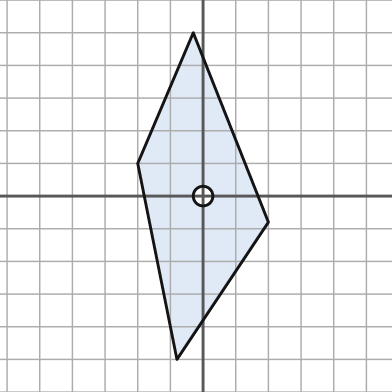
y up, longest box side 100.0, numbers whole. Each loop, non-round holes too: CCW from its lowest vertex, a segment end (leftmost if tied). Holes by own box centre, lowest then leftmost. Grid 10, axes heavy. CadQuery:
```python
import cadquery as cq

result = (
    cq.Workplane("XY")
    .moveTo(-8.0, -50.0)
    .lineTo(20.0, -8.0)
    .lineTo(-3.0, 50.0)
    .lineTo(-20.0, 10.0)
    .close()
    .moveTo(0.0, 0.0)
    .circle(3.0)
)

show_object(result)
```